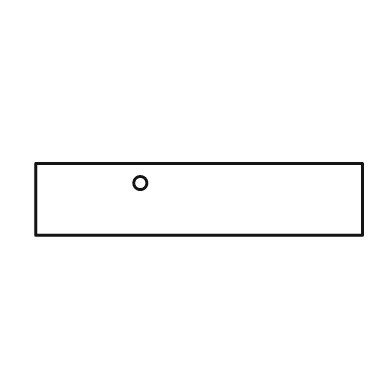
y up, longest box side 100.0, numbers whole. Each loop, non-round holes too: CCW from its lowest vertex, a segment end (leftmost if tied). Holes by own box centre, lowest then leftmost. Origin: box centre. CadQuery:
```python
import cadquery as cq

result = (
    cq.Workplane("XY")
    .moveTo(-50.0, -11.0)
    .lineTo(50.0, -11.0)
    .lineTo(50.0, 11.0)
    .lineTo(-50.0, 11.0)
    .close()
    .moveTo(-18.0, 5.0)
    .circle(2.0)
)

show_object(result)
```